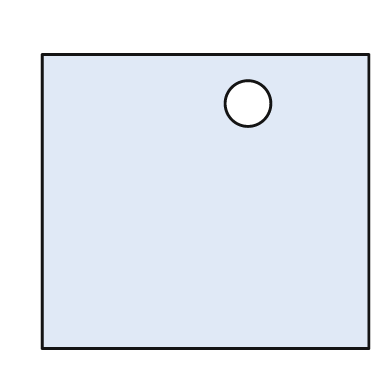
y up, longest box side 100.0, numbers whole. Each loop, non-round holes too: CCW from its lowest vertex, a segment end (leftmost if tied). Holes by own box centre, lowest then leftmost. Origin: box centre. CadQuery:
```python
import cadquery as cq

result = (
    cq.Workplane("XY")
    .moveTo(-50.0, -45.0)
    .lineTo(50.0, -45.0)
    .lineTo(50.0, 45.0)
    .lineTo(-50.0, 45.0)
    .close()
    .moveTo(13.0, 30.0)
    .circle(7.0)
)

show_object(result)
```